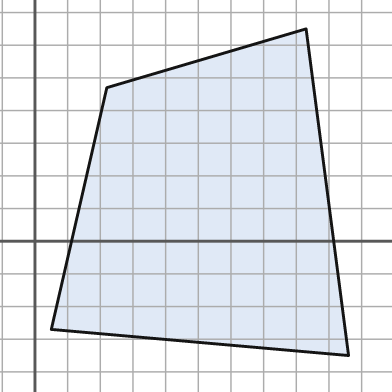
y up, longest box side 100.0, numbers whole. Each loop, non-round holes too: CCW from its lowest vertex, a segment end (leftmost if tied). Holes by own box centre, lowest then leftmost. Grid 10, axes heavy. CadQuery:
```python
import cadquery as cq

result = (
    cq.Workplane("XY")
    .moveTo(96.0, -35.0)
    .lineTo(83.0, 65.0)
    .lineTo(22.0, 47.0)
    .lineTo(5.0, -27.0)
    .close()
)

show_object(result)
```